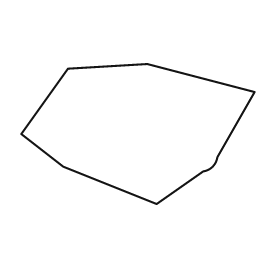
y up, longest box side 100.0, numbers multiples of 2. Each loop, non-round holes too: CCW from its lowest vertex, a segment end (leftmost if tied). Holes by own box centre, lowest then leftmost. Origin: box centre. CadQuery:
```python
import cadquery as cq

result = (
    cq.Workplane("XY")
    .moveTo(8.0, -30.0)
    .lineTo(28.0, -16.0)
    .threePointArc((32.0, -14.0), (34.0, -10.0))
    .lineTo(50.0, 18.0)
    .lineTo(4.0, 30.0)
    .lineTo(-30.0, 28.0)
    .lineTo(-50.0, 0.0)
    .lineTo(-32.0, -14.0)
    .close()
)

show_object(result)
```